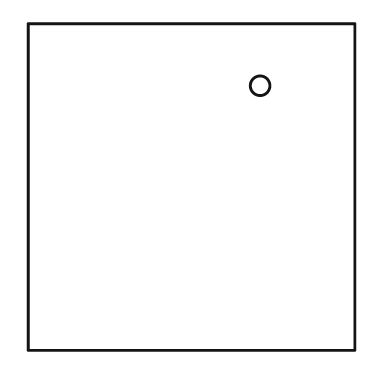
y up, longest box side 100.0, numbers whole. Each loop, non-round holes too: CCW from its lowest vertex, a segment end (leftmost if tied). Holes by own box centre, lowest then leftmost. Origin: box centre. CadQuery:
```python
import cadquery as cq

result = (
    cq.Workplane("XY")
    .moveTo(-50.0, -50.0)
    .lineTo(50.0, -50.0)
    .lineTo(50.0, 50.0)
    .lineTo(-50.0, 50.0)
    .close()
    .moveTo(21.0, 31.0)
    .circle(3.0)
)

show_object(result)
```